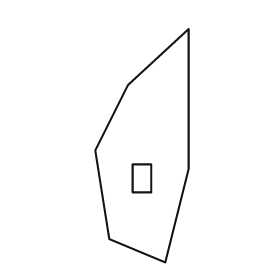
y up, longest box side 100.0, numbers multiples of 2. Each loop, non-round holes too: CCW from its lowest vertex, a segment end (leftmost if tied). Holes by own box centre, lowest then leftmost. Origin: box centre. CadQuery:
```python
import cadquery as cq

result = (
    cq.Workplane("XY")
    .moveTo(10.0, -50.0)
    .lineTo(20.0, -10.0)
    .lineTo(20.0, 50.0)
    .lineTo(-6.0, 26.0)
    .lineTo(-20.0, -2.0)
    .lineTo(-14.0, -40.0)
    .close()
    .moveTo(-4.0, -20.0)
    .lineTo(4.0, -20.0)
    .lineTo(4.0, -8.0)
    .lineTo(-4.0, -8.0)
    .close()
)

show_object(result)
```